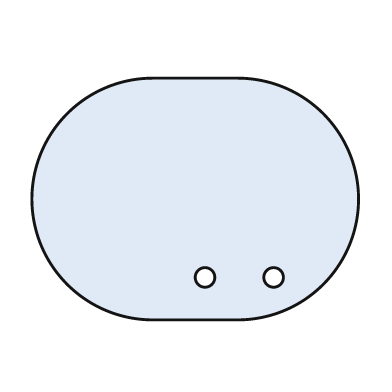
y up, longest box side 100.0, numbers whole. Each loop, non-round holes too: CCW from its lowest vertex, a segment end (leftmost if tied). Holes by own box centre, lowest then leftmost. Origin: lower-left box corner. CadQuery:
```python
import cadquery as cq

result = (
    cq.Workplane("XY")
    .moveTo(37.0, 0.0)
    .lineTo(63.0, 0.0)
    .threePointArc((100.0, 37.0), (63.0, 74.0))
    .lineTo(37.0, 74.0)
    .threePointArc((0.0, 37.0), (37.0, 0.0))
    .close()
    .moveTo(53.0, 13.0)
    .circle(3.0)
    .moveTo(74.0, 13.0)
    .circle(3.0)
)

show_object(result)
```